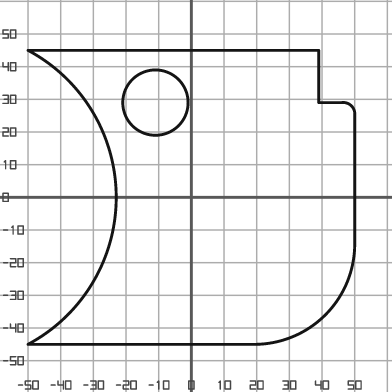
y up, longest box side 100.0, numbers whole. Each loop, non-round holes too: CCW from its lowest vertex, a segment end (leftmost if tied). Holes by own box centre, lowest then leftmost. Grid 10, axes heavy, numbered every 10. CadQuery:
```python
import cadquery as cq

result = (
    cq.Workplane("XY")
    .moveTo(-50.0, -45.0)
    .lineTo(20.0, -45.0)
    .threePointArc((41.0, -36.0), (50.0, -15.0))
    .lineTo(50.0, 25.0)
    .threePointArc((49.0, 28.0), (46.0, 29.0))
    .lineTo(39.0, 29.0)
    .lineTo(39.0, 45.0)
    .lineTo(-50.0, 45.0)
    .threePointArc((-23.0, 0.0), (-50.0, -45.0))
    .close()
    .moveTo(-11.0, 29.0)
    .circle(10.0)
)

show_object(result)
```